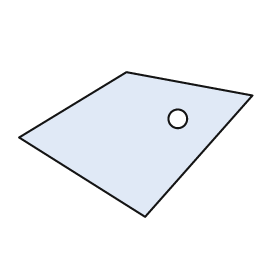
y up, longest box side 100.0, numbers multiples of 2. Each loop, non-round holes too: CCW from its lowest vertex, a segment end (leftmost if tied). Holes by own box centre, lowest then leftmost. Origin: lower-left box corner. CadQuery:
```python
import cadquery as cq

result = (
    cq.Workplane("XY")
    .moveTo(54.0, 0.0)
    .lineTo(100.0, 52.0)
    .lineTo(46.0, 62.0)
    .lineTo(0.0, 34.0)
    .close()
    .moveTo(68.0, 42.0)
    .circle(4.0)
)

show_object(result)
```